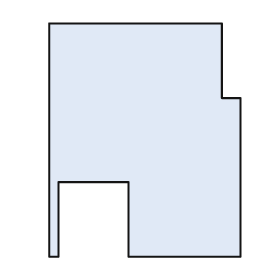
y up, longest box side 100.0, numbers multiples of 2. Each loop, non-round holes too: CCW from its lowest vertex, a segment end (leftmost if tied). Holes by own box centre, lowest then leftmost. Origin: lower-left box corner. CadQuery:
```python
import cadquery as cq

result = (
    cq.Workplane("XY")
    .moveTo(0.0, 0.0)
    .lineTo(4.0, 0.0)
    .lineTo(4.0, 32.0)
    .lineTo(34.0, 32.0)
    .lineTo(34.0, 0.0)
    .lineTo(82.0, 0.0)
    .lineTo(82.0, 68.0)
    .lineTo(74.0, 68.0)
    .lineTo(74.0, 100.0)
    .lineTo(0.0, 100.0)
    .close()
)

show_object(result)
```